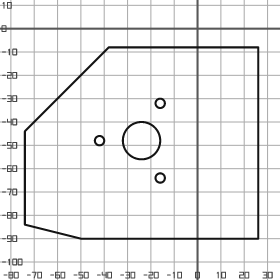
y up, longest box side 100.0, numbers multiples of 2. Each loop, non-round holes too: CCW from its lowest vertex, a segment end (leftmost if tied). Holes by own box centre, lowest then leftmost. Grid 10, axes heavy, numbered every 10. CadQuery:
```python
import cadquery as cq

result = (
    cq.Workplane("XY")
    .moveTo(-50.0, -90.0)
    .lineTo(26.0, -90.0)
    .lineTo(26.0, -8.0)
    .lineTo(-38.0, -8.0)
    .lineTo(-74.0, -44.0)
    .lineTo(-74.0, -84.0)
    .close()
    .moveTo(-16.0, -64.0)
    .circle(2.0)
    .moveTo(-42.0, -48.0)
    .circle(2.0)
    .moveTo(-24.0, -48.0)
    .circle(8.0)
    .moveTo(-16.0, -32.0)
    .circle(2.0)
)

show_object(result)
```